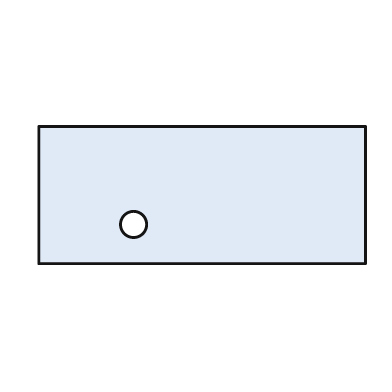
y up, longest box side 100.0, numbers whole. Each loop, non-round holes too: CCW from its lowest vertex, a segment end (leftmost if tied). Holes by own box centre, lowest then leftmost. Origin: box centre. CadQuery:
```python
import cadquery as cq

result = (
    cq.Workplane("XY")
    .moveTo(-50.0, -21.0)
    .lineTo(50.0, -21.0)
    .lineTo(50.0, 21.0)
    .lineTo(-50.0, 21.0)
    .close()
    .moveTo(-21.0, -9.0)
    .circle(4.0)
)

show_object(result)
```